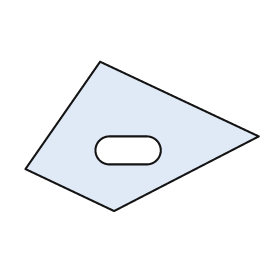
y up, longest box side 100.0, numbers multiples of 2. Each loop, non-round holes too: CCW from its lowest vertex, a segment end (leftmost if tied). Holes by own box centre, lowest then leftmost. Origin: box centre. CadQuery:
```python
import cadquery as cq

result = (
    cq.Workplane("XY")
    .moveTo(-12.0, -32.0)
    .lineTo(50.0, 0.0)
    .lineTo(-18.0, 32.0)
    .lineTo(-50.0, -14.0)
    .close()
    .moveTo(-14.0, -12.0)
    .lineTo(2.0, -12.0)
    .threePointArc((8.0, -6.0), (2.0, 0.0))
    .lineTo(-14.0, 0.0)
    .threePointArc((-20.0, -6.0), (-14.0, -12.0))
    .close()
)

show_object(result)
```